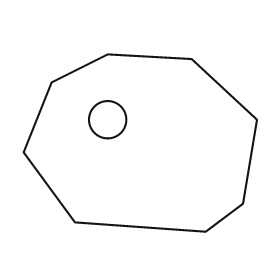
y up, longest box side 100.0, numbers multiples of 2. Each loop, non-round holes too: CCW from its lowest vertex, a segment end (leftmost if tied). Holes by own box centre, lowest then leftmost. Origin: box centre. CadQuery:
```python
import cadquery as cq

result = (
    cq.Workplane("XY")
    .moveTo(28.0, -38.0)
    .lineTo(44.0, -26.0)
    .lineTo(50.0, 10.0)
    .lineTo(22.0, 36.0)
    .lineTo(-14.0, 38.0)
    .lineTo(-38.0, 26.0)
    .lineTo(-50.0, -4.0)
    .lineTo(-28.0, -34.0)
    .close()
    .moveTo(-14.0, 10.0)
    .circle(8.0)
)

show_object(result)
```